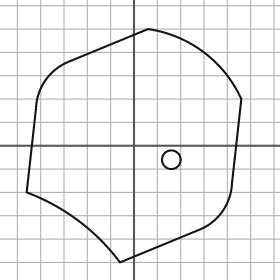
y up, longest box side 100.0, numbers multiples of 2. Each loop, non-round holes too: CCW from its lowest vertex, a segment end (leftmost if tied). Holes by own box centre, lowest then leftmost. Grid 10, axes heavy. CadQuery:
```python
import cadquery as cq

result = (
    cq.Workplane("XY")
    .moveTo(-6.0, -50.0)
    .lineTo(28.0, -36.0)
    .threePointArc((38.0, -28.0), (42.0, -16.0))
    .lineTo(46.0, 20.0)
    .threePointArc((30.0, 40.0), (6.0, 50.0))
    .lineTo(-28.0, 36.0)
    .threePointArc((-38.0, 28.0), (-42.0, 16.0))
    .lineTo(-46.0, -20.0)
    .threePointArc((-24.0, -32.0), (-6.0, -50.0))
    .close()
    .moveTo(16.0, -6.0)
    .circle(4.0)
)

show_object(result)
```